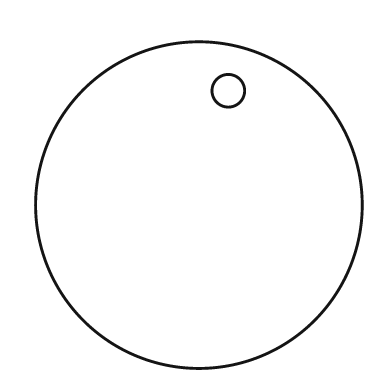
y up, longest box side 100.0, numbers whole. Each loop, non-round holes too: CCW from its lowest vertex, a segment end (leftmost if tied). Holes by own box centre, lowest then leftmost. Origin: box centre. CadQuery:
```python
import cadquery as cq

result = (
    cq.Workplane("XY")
    .moveTo(0.0, 0.0)
    .circle(50.0)
    .moveTo(9.0, 35.0)
    .circle(5.0)
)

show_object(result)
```